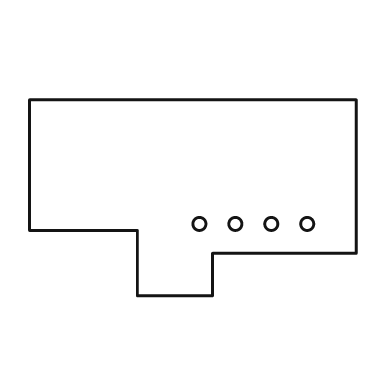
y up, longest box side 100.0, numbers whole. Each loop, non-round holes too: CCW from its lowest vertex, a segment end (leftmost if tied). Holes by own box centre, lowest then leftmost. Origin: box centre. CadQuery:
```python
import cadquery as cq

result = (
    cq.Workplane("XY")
    .moveTo(-17.0, -30.0)
    .lineTo(6.0, -30.0)
    .lineTo(6.0, -17.0)
    .lineTo(50.0, -17.0)
    .lineTo(50.0, 30.0)
    .lineTo(-50.0, 30.0)
    .lineTo(-50.0, -10.0)
    .lineTo(-17.0, -10.0)
    .close()
    .moveTo(2.0, -8.0)
    .circle(2.0)
    .moveTo(13.0, -8.0)
    .circle(2.0)
    .moveTo(24.0, -8.0)
    .circle(2.0)
    .moveTo(35.0, -8.0)
    .circle(2.0)
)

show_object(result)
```